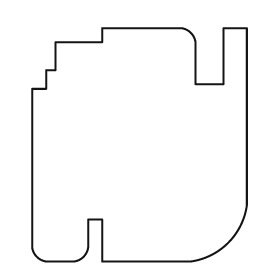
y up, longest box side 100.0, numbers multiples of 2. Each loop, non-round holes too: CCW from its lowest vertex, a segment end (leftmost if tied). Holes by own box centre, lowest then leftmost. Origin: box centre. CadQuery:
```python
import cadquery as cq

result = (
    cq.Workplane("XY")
    .moveTo(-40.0, -50.0)
    .lineTo(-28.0, -50.0)
    .threePointArc((-24.0, -48.0), (-22.0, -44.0))
    .lineTo(-22.0, -32.0)
    .lineTo(-16.0, -32.0)
    .lineTo(-16.0, -50.0)
    .lineTo(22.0, -50.0)
    .threePointArc((38.0, -42.0), (46.0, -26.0))
    .lineTo(46.0, 50.0)
    .lineTo(36.0, 50.0)
    .lineTo(36.0, 26.0)
    .lineTo(24.0, 26.0)
    .lineTo(24.0, 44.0)
    .threePointArc((22.0, 48.0), (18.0, 50.0))
    .lineTo(-16.0, 50.0)
    .lineTo(-16.0, 44.0)
    .lineTo(-36.0, 44.0)
    .lineTo(-36.0, 32.0)
    .lineTo(-40.0, 32.0)
    .lineTo(-40.0, 24.0)
    .lineTo(-46.0, 24.0)
    .lineTo(-46.0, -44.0)
    .threePointArc((-44.0, -48.0), (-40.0, -50.0))
    .close()
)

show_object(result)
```